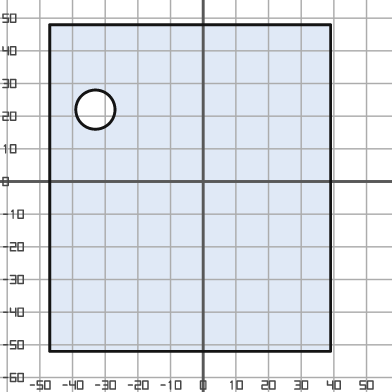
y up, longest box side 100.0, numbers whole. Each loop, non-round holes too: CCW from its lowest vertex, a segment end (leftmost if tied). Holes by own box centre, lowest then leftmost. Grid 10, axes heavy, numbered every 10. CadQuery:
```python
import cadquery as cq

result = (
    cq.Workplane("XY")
    .moveTo(-47.0, -52.0)
    .lineTo(39.0, -52.0)
    .lineTo(39.0, 48.0)
    .lineTo(-47.0, 48.0)
    .close()
    .moveTo(-33.0, 22.0)
    .circle(6.0)
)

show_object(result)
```